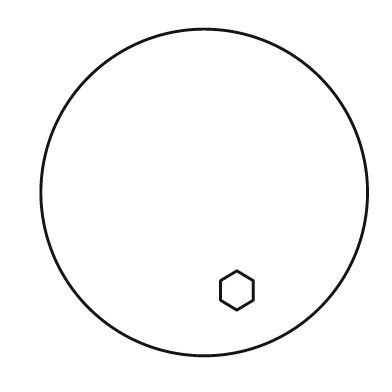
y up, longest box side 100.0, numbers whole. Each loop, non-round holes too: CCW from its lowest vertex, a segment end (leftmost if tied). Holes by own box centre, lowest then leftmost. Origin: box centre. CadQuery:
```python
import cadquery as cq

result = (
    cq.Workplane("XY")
    .moveTo(0.0, 0.0)
    .circle(50.0)
    .moveTo(10.0, -36.0)
    .lineTo(15.0, -33.0)
    .lineTo(15.0, -27.0)
    .lineTo(10.0, -24.0)
    .lineTo(5.0, -27.0)
    .lineTo(5.0, -33.0)
    .close()
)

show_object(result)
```